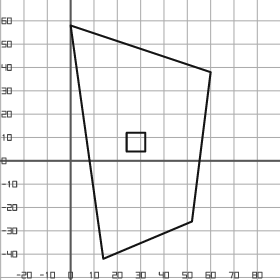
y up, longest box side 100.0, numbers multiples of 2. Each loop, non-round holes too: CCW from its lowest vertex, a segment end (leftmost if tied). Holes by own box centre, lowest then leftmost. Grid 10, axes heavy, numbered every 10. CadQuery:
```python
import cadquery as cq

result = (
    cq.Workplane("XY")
    .moveTo(14.0, -42.0)
    .lineTo(52.0, -26.0)
    .lineTo(60.0, 38.0)
    .lineTo(0.0, 58.0)
    .close()
    .moveTo(24.0, 4.0)
    .lineTo(32.0, 4.0)
    .lineTo(32.0, 12.0)
    .lineTo(24.0, 12.0)
    .close()
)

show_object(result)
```